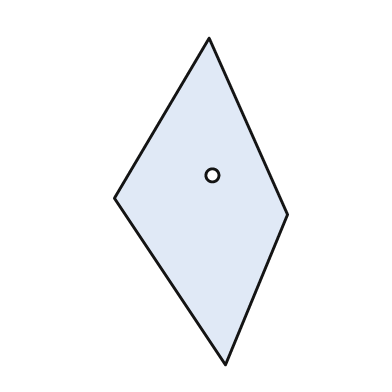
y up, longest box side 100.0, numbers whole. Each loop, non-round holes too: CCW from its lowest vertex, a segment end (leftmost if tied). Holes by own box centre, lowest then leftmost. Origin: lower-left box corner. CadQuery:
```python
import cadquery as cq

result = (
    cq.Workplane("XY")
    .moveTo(34.0, 0.0)
    .lineTo(53.0, 46.0)
    .lineTo(29.0, 100.0)
    .lineTo(0.0, 51.0)
    .close()
    .moveTo(30.0, 58.0)
    .circle(2.0)
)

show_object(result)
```